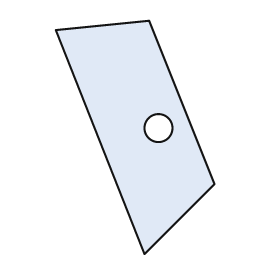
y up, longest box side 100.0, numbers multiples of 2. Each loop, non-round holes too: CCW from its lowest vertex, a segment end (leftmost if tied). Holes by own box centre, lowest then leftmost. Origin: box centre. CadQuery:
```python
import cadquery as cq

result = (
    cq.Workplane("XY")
    .moveTo(4.0, -50.0)
    .lineTo(34.0, -20.0)
    .lineTo(6.0, 50.0)
    .lineTo(-34.0, 46.0)
    .close()
    .moveTo(10.0, 4.0)
    .circle(6.0)
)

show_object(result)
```